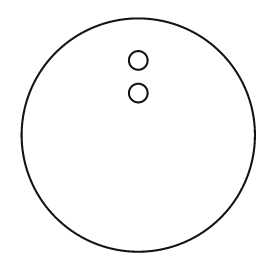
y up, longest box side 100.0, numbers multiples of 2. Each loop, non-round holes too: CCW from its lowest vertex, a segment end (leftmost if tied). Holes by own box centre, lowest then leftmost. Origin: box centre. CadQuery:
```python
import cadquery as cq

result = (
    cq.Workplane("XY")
    .moveTo(0.0, 0.0)
    .circle(50.0)
    .moveTo(0.0, 18.0)
    .circle(4.0)
    .moveTo(0.0, 32.0)
    .circle(4.0)
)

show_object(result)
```